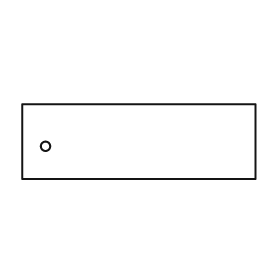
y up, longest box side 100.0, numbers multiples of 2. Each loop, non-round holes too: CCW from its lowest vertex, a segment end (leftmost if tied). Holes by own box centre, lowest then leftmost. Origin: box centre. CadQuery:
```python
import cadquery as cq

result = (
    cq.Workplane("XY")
    .moveTo(-50.0, -16.0)
    .lineTo(50.0, -16.0)
    .lineTo(50.0, 16.0)
    .lineTo(-50.0, 16.0)
    .close()
    .moveTo(-40.0, -2.0)
    .circle(2.0)
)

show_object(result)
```